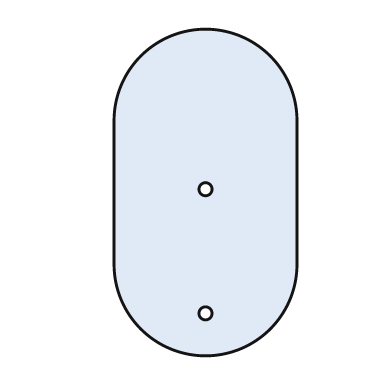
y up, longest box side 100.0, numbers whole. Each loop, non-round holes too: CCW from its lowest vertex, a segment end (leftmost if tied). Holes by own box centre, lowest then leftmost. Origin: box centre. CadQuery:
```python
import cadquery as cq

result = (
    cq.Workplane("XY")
    .moveTo(-28.0, -22.0)
    .threePointArc((0.0, -50.0), (28.0, -22.0))
    .lineTo(28.0, 22.0)
    .threePointArc((0.0, 50.0), (-28.0, 22.0))
    .close()
    .moveTo(0.0, -37.0)
    .circle(2.0)
    .moveTo(0.0, 1.0)
    .circle(2.0)
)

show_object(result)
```